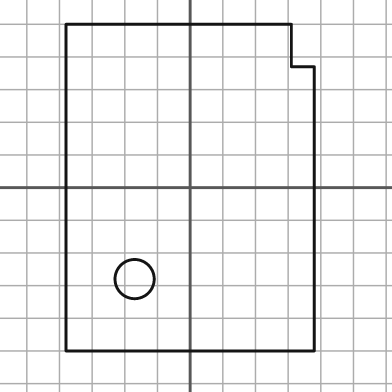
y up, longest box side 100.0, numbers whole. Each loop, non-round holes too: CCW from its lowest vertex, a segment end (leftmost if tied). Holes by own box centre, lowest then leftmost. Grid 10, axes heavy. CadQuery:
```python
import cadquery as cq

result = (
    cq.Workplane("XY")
    .moveTo(-38.0, -50.0)
    .lineTo(38.0, -50.0)
    .lineTo(38.0, 37.0)
    .lineTo(31.0, 37.0)
    .lineTo(31.0, 50.0)
    .lineTo(-38.0, 50.0)
    .close()
    .moveTo(-17.0, -28.0)
    .circle(6.0)
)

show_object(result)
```